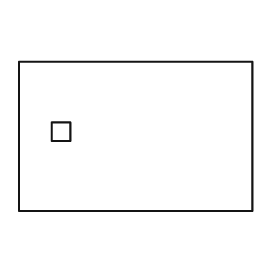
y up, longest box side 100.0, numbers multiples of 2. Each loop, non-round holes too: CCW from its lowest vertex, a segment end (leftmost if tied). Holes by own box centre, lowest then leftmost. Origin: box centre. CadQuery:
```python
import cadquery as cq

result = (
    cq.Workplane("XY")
    .moveTo(-50.0, -32.0)
    .lineTo(50.0, -32.0)
    .lineTo(50.0, 32.0)
    .lineTo(-50.0, 32.0)
    .close()
    .moveTo(-36.0, -2.0)
    .lineTo(-28.0, -2.0)
    .lineTo(-28.0, 6.0)
    .lineTo(-36.0, 6.0)
    .close()
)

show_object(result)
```